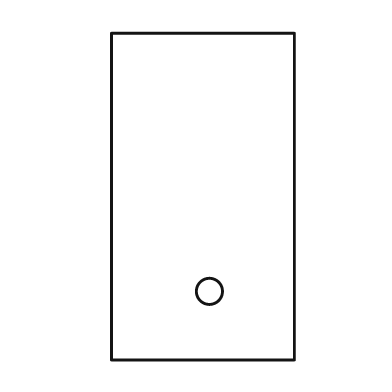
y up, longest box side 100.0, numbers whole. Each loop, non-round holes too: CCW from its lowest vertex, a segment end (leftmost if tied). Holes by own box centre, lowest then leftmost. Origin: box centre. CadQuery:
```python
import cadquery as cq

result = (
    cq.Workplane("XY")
    .moveTo(-28.0, -50.0)
    .lineTo(28.0, -50.0)
    .lineTo(28.0, 50.0)
    .lineTo(-28.0, 50.0)
    .close()
    .moveTo(2.0, -29.0)
    .circle(4.0)
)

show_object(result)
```